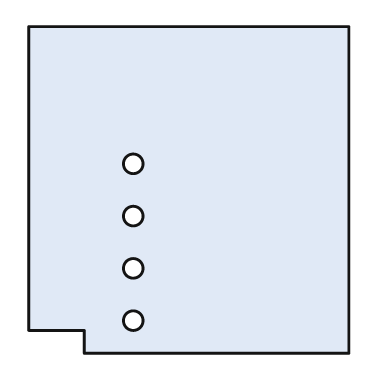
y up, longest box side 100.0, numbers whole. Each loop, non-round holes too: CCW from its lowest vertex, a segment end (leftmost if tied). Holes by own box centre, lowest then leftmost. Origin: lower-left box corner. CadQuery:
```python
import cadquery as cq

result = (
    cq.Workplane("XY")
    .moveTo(17.0, 0.0)
    .lineTo(98.0, 0.0)
    .lineTo(98.0, 100.0)
    .lineTo(0.0, 100.0)
    .lineTo(0.0, 7.0)
    .lineTo(17.0, 7.0)
    .close()
    .moveTo(32.0, 10.0)
    .circle(3.0)
    .moveTo(32.0, 26.0)
    .circle(3.0)
    .moveTo(32.0, 42.0)
    .circle(3.0)
    .moveTo(32.0, 58.0)
    .circle(3.0)
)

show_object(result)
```